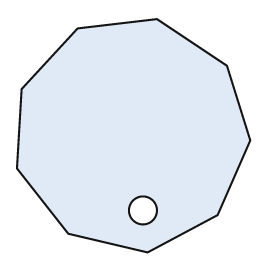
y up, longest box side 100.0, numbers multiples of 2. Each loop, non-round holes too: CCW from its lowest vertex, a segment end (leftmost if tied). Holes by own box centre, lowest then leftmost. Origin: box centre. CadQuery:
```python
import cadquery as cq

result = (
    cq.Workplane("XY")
    .moveTo(6.0, -50.0)
    .lineTo(36.0, -34.0)
    .lineTo(50.0, -2.0)
    .lineTo(40.0, 30.0)
    .lineTo(10.0, 50.0)
    .lineTo(-24.0, 46.0)
    .lineTo(-48.0, 20.0)
    .lineTo(-50.0, -14.0)
    .lineTo(-28.0, -42.0)
    .close()
    .moveTo(4.0, -32.0)
    .circle(6.0)
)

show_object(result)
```